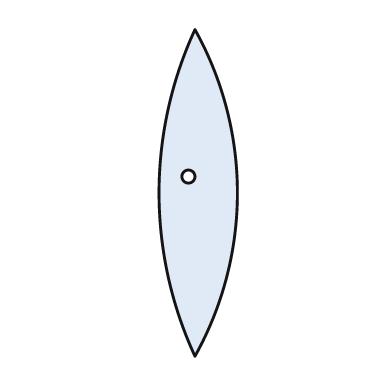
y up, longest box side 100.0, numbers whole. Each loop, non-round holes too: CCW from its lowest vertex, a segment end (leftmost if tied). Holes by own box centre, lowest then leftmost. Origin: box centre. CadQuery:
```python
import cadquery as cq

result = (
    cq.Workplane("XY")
    .moveTo(-1.0, -50.0)
    .threePointArc((12.0, 0.0), (-1.0, 50.0))
    .threePointArc((-12.0, 0.0), (-1.0, -50.0))
    .close()
    .moveTo(-3.0, 5.0)
    .circle(2.0)
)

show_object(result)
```